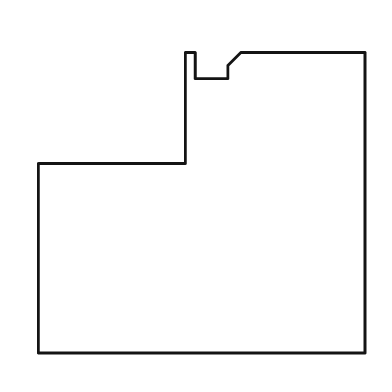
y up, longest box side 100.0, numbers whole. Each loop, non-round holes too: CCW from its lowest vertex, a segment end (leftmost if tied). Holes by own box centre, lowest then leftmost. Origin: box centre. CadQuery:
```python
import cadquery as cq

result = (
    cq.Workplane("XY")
    .moveTo(-50.0, -46.0)
    .lineTo(50.0, -46.0)
    .lineTo(50.0, 46.0)
    .lineTo(12.0, 46.0)
    .lineTo(8.0, 42.0)
    .lineTo(8.0, 38.0)
    .lineTo(-2.0, 38.0)
    .lineTo(-2.0, 46.0)
    .lineTo(-5.0, 46.0)
    .lineTo(-5.0, 12.0)
    .lineTo(-50.0, 12.0)
    .close()
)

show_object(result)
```